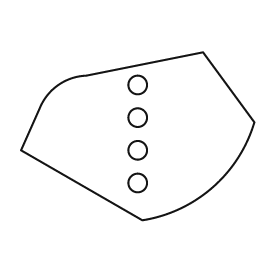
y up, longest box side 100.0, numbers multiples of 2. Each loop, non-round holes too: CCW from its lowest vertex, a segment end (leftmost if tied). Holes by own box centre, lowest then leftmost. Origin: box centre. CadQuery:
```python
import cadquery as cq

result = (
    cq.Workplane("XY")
    .moveTo(2.0, -36.0)
    .threePointArc((32.0, -22.0), (50.0, 6.0))
    .lineTo(28.0, 36.0)
    .lineTo(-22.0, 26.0)
    .threePointArc((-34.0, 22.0), (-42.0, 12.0))
    .lineTo(-50.0, -6.0)
    .close()
    .moveTo(0.0, -20.0)
    .circle(4.0)
    .moveTo(0.0, -6.0)
    .circle(4.0)
    .moveTo(0.0, 8.0)
    .circle(4.0)
    .moveTo(0.0, 22.0)
    .circle(4.0)
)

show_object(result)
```